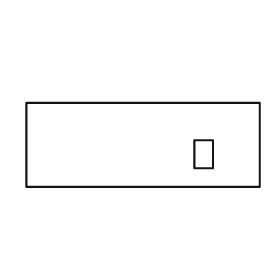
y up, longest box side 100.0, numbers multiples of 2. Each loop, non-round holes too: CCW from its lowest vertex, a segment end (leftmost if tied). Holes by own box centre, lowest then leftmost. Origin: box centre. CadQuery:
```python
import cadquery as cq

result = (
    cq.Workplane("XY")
    .moveTo(-50.0, -18.0)
    .lineTo(50.0, -18.0)
    .lineTo(50.0, 18.0)
    .lineTo(-50.0, 18.0)
    .close()
    .moveTo(22.0, -10.0)
    .lineTo(30.0, -10.0)
    .lineTo(30.0, 2.0)
    .lineTo(22.0, 2.0)
    .close()
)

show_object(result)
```